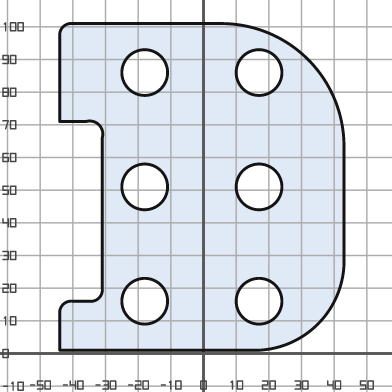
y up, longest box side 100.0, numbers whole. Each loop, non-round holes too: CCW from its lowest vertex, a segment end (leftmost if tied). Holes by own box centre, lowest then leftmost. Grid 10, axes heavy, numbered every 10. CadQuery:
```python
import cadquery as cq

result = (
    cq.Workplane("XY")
    .moveTo(-44.0, 1.0)
    .lineTo(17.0, 1.0)
    .threePointArc((35.0, 9.0), (43.0, 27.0))
    .lineTo(43.0, 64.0)
    .threePointArc((32.0, 90.0), (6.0, 101.0))
    .lineTo(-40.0, 101.0)
    .threePointArc((-43.0, 100.0), (-44.0, 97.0))
    .lineTo(-44.0, 71.0)
    .lineTo(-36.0, 71.0)
    .threePointArc((-32.0, 70.0), (-31.0, 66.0))
    .lineTo(-31.0, 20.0)
    .threePointArc((-32.0, 17.0), (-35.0, 16.0))
    .lineTo(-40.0, 16.0)
    .threePointArc((-43.0, 15.0), (-44.0, 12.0))
    .close()
    .moveTo(-18.0, 16.0)
    .circle(7.0)
    .moveTo(17.0, 16.0)
    .circle(7.0)
    .moveTo(-18.0, 51.0)
    .circle(7.0)
    .moveTo(17.0, 51.0)
    .circle(7.0)
    .moveTo(-18.0, 86.0)
    .circle(7.0)
    .moveTo(17.0, 86.0)
    .circle(7.0)
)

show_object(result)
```